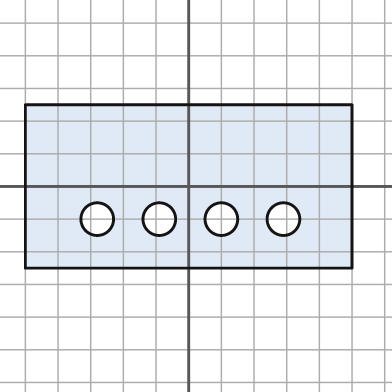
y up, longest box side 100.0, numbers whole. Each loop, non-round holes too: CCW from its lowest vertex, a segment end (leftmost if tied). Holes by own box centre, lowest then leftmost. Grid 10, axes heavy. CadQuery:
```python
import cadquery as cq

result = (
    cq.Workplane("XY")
    .moveTo(-50.0, -25.0)
    .lineTo(50.0, -25.0)
    .lineTo(50.0, 25.0)
    .lineTo(-50.0, 25.0)
    .close()
    .moveTo(-28.0, -10.0)
    .circle(5.0)
    .moveTo(-9.0, -10.0)
    .circle(5.0)
    .moveTo(10.0, -10.0)
    .circle(5.0)
    .moveTo(29.0, -10.0)
    .circle(5.0)
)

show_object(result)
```